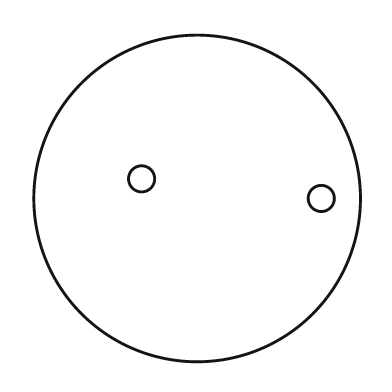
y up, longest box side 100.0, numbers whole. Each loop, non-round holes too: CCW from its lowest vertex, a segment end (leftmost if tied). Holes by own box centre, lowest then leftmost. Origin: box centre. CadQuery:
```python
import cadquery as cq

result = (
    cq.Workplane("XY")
    .moveTo(0.0, 0.0)
    .circle(50.0)
    .moveTo(38.0, 0.0)
    .circle(4.0)
    .moveTo(-17.0, 6.0)
    .circle(4.0)
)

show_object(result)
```